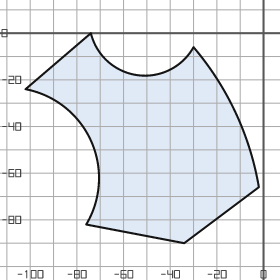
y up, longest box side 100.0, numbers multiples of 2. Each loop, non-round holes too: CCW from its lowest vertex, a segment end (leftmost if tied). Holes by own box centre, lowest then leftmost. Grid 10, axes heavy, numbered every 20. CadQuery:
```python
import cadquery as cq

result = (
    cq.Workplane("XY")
    .moveTo(-34.0, -90.0)
    .lineTo(-2.0, -66.0)
    .threePointArc((-12.0, -34.0), (-30.0, -6.0))
    .threePointArc((-54.0, -18.0), (-74.0, 0.0))
    .lineTo(-102.0, -24.0)
    .threePointArc((-74.0, -46.0), (-76.0, -82.0))
    .close()
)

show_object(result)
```